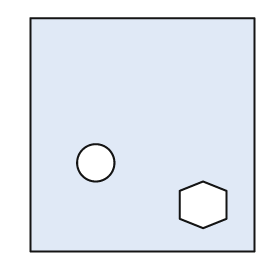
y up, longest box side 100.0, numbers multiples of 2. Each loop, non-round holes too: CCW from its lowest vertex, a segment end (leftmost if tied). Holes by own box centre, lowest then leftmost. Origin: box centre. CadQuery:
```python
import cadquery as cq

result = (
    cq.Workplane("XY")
    .moveTo(-48.0, -50.0)
    .lineTo(48.0, -50.0)
    .lineTo(48.0, 50.0)
    .lineTo(-48.0, 50.0)
    .close()
    .moveTo(26.0, -40.0)
    .lineTo(36.0, -36.0)
    .lineTo(36.0, -24.0)
    .lineTo(26.0, -20.0)
    .lineTo(16.0, -24.0)
    .lineTo(16.0, -36.0)
    .close()
    .moveTo(-20.0, -12.0)
    .circle(8.0)
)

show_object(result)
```